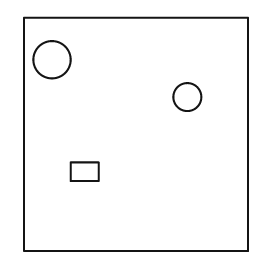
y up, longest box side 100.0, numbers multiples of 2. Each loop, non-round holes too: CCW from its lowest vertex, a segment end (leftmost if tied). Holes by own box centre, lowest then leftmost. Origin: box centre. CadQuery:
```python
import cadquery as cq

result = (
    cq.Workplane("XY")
    .moveTo(-48.0, -50.0)
    .lineTo(48.0, -50.0)
    .lineTo(48.0, 50.0)
    .lineTo(-48.0, 50.0)
    .close()
    .moveTo(-28.0, -20.0)
    .lineTo(-16.0, -20.0)
    .lineTo(-16.0, -12.0)
    .lineTo(-28.0, -12.0)
    .close()
    .moveTo(22.0, 16.0)
    .circle(6.0)
    .moveTo(-36.0, 32.0)
    .circle(8.0)
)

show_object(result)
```